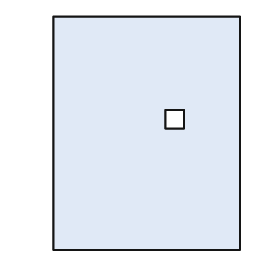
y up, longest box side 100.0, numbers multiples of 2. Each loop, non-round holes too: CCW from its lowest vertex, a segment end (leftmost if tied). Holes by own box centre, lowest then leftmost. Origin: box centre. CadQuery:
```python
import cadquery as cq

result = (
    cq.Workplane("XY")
    .moveTo(-40.0, -50.0)
    .lineTo(40.0, -50.0)
    .lineTo(40.0, 50.0)
    .lineTo(-40.0, 50.0)
    .close()
    .moveTo(8.0, 2.0)
    .lineTo(16.0, 2.0)
    .lineTo(16.0, 10.0)
    .lineTo(8.0, 10.0)
    .close()
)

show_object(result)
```